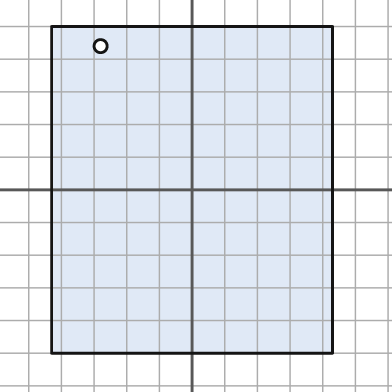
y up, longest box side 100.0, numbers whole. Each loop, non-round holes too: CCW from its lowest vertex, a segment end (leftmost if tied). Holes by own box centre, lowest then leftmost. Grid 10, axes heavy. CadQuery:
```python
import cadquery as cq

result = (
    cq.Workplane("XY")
    .moveTo(-43.0, -50.0)
    .lineTo(43.0, -50.0)
    .lineTo(43.0, 50.0)
    .lineTo(-43.0, 50.0)
    .close()
    .moveTo(-28.0, 44.0)
    .circle(2.0)
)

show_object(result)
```